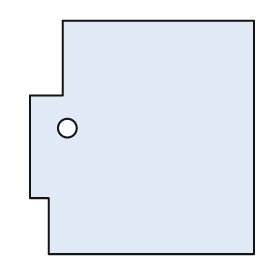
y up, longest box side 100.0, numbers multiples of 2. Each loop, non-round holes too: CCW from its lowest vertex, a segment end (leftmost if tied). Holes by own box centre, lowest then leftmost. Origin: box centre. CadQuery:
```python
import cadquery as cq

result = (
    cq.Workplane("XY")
    .moveTo(-40.0, -50.0)
    .lineTo(48.0, -50.0)
    .lineTo(48.0, 50.0)
    .lineTo(-34.0, 50.0)
    .lineTo(-34.0, 18.0)
    .lineTo(-48.0, 18.0)
    .lineTo(-48.0, -26.0)
    .lineTo(-40.0, -26.0)
    .close()
    .moveTo(-32.0, 4.0)
    .circle(4.0)
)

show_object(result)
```